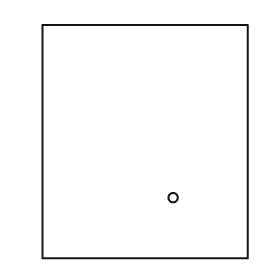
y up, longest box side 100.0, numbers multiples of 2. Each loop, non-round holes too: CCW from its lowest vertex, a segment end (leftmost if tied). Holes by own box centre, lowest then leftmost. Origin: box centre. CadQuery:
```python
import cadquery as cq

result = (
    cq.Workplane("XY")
    .moveTo(-44.0, -50.0)
    .lineTo(44.0, -50.0)
    .lineTo(44.0, 50.0)
    .lineTo(-44.0, 50.0)
    .close()
    .moveTo(12.0, -24.0)
    .circle(2.0)
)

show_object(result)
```